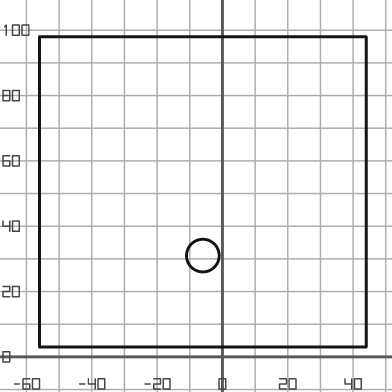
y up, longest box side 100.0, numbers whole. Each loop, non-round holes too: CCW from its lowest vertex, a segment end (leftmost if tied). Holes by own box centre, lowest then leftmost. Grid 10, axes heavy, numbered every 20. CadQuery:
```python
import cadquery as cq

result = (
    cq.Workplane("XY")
    .moveTo(-56.0, 3.0)
    .lineTo(44.0, 3.0)
    .lineTo(44.0, 98.0)
    .lineTo(-56.0, 98.0)
    .close()
    .moveTo(-6.0, 31.0)
    .circle(5.0)
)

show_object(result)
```